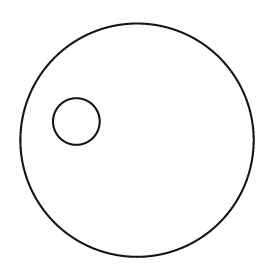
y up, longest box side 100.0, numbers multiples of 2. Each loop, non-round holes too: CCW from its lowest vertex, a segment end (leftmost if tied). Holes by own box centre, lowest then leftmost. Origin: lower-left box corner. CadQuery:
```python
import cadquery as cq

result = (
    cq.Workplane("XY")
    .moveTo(50.0, 50.0)
    .circle(50.0)
    .moveTo(24.0, 58.0)
    .circle(10.0)
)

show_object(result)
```